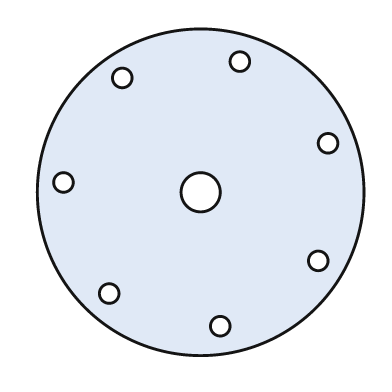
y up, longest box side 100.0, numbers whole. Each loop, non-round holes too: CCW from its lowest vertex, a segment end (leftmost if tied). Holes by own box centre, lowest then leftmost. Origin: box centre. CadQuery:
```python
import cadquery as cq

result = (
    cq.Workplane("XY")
    .moveTo(0.0, 0.0)
    .circle(50.0)
    .moveTo(6.0, -41.0)
    .circle(3.0)
    .moveTo(-28.0, -31.0)
    .circle(3.0)
    .moveTo(36.0, -21.0)
    .circle(3.0)
    .moveTo(0.0, 0.0)
    .circle(6.0)
    .moveTo(-42.0, 3.0)
    .circle(3.0)
    .moveTo(39.0, 15.0)
    .circle(3.0)
    .moveTo(-24.0, 35.0)
    .circle(3.0)
    .moveTo(12.0, 40.0)
    .circle(3.0)
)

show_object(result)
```